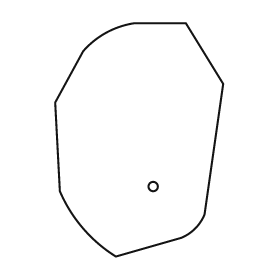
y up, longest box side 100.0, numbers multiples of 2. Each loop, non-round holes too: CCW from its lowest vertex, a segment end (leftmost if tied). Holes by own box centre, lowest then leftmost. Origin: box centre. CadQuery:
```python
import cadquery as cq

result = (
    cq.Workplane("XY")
    .moveTo(-10.0, -50.0)
    .lineTo(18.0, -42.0)
    .threePointArc((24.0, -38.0), (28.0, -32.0))
    .lineTo(36.0, 24.0)
    .lineTo(20.0, 50.0)
    .lineTo(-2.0, 50.0)
    .threePointArc((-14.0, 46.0), (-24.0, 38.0))
    .lineTo(-36.0, 16.0)
    .lineTo(-34.0, -22.0)
    .threePointArc((-24.0, -38.0), (-10.0, -50.0))
    .close()
    .moveTo(6.0, -20.0)
    .circle(2.0)
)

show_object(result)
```